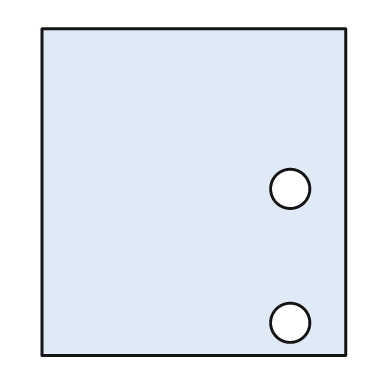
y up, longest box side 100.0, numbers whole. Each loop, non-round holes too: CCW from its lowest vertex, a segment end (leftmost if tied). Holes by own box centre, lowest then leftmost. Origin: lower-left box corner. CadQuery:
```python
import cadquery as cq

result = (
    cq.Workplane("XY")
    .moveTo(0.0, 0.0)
    .lineTo(93.0, 0.0)
    .lineTo(93.0, 100.0)
    .lineTo(0.0, 100.0)
    .close()
    .moveTo(76.0, 10.0)
    .circle(6.0)
    .moveTo(76.0, 51.0)
    .circle(6.0)
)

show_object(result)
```